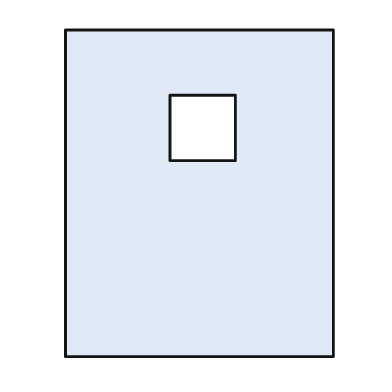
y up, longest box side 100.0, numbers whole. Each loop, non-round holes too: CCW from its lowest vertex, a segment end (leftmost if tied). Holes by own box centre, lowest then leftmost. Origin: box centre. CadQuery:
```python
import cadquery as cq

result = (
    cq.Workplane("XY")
    .moveTo(-41.0, -50.0)
    .lineTo(41.0, -50.0)
    .lineTo(41.0, 50.0)
    .lineTo(-41.0, 50.0)
    .close()
    .moveTo(-9.0, 10.0)
    .lineTo(11.0, 10.0)
    .lineTo(11.0, 30.0)
    .lineTo(-9.0, 30.0)
    .close()
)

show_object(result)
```